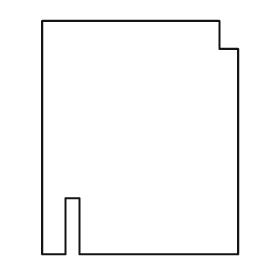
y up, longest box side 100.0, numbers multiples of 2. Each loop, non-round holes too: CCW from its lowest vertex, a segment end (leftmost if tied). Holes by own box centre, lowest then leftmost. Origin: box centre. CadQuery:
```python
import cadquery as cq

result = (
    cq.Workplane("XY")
    .moveTo(-42.0, -50.0)
    .lineTo(-32.0, -50.0)
    .lineTo(-32.0, -26.0)
    .lineTo(-26.0, -26.0)
    .lineTo(-26.0, -50.0)
    .lineTo(42.0, -50.0)
    .lineTo(42.0, 38.0)
    .lineTo(34.0, 38.0)
    .lineTo(34.0, 50.0)
    .lineTo(-42.0, 50.0)
    .close()
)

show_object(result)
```